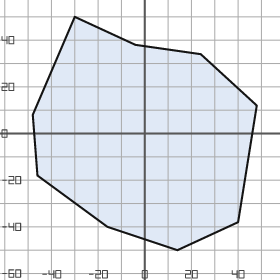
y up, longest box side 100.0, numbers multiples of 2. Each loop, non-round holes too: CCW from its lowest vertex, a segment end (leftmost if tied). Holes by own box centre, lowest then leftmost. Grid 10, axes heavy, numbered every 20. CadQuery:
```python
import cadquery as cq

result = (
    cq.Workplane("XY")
    .moveTo(14.0, -50.0)
    .lineTo(40.0, -38.0)
    .lineTo(48.0, 12.0)
    .lineTo(24.0, 34.0)
    .lineTo(-4.0, 38.0)
    .lineTo(-30.0, 50.0)
    .lineTo(-48.0, 8.0)
    .lineTo(-46.0, -18.0)
    .lineTo(-16.0, -40.0)
    .close()
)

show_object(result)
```